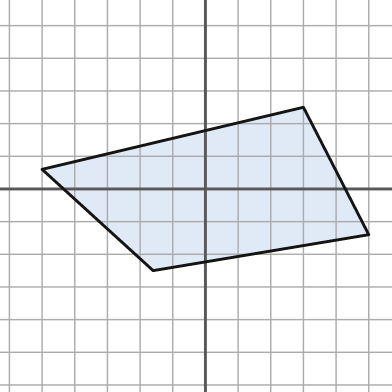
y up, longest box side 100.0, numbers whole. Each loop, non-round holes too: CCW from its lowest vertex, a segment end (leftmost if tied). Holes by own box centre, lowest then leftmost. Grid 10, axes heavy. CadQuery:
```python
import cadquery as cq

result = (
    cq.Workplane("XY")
    .moveTo(-16.0, -25.0)
    .lineTo(50.0, -14.0)
    .lineTo(30.0, 25.0)
    .lineTo(-50.0, 6.0)
    .close()
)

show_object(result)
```